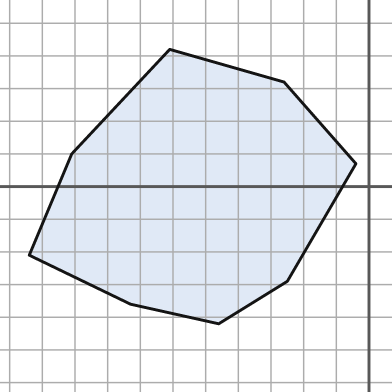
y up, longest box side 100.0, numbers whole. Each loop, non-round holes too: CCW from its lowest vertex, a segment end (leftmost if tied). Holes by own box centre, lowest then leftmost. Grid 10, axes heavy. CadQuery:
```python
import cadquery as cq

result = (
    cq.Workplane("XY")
    .moveTo(-46.0, -42.0)
    .lineTo(-25.0, -29.0)
    .lineTo(-4.0, 7.0)
    .lineTo(-26.0, 32.0)
    .lineTo(-61.0, 42.0)
    .lineTo(-91.0, 10.0)
    .lineTo(-104.0, -21.0)
    .lineTo(-73.0, -36.0)
    .close()
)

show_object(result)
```